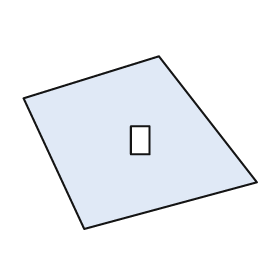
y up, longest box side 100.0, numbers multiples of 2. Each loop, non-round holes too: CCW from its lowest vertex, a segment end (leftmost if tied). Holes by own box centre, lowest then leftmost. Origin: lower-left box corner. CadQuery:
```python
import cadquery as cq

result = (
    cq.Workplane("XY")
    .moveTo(26.0, 0.0)
    .lineTo(100.0, 20.0)
    .lineTo(58.0, 74.0)
    .lineTo(0.0, 56.0)
    .close()
    .moveTo(46.0, 32.0)
    .lineTo(54.0, 32.0)
    .lineTo(54.0, 44.0)
    .lineTo(46.0, 44.0)
    .close()
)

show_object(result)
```